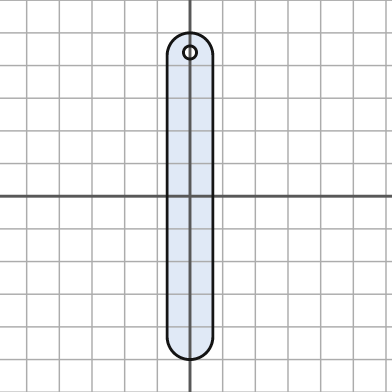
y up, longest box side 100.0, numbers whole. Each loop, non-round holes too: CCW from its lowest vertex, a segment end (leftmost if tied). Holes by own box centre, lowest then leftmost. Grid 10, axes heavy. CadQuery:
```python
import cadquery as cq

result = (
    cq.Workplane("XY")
    .moveTo(-7.0, -43.0)
    .threePointArc((0.0, -50.0), (7.0, -43.0))
    .lineTo(7.0, 43.0)
    .threePointArc((0.0, 50.0), (-7.0, 43.0))
    .close()
    .moveTo(0.0, 44.0)
    .circle(2.0)
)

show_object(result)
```